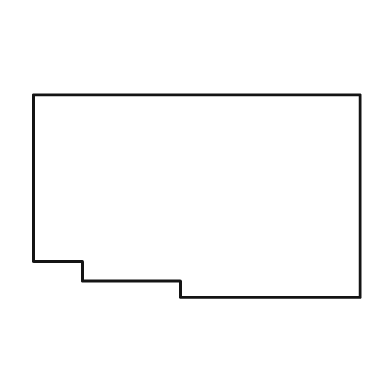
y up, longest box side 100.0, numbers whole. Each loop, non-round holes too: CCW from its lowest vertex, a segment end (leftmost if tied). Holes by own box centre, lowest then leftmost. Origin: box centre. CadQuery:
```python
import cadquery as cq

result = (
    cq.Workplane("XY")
    .moveTo(-5.0, -31.0)
    .lineTo(50.0, -31.0)
    .lineTo(50.0, 31.0)
    .lineTo(-50.0, 31.0)
    .lineTo(-50.0, -20.0)
    .lineTo(-35.0, -20.0)
    .lineTo(-35.0, -26.0)
    .lineTo(-5.0, -26.0)
    .close()
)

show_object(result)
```